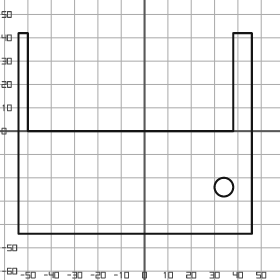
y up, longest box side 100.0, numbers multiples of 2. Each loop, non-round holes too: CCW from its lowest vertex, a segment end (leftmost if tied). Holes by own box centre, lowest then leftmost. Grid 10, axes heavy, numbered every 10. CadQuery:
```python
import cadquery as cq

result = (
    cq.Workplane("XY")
    .moveTo(-54.0, -44.0)
    .lineTo(46.0, -44.0)
    .lineTo(46.0, 42.0)
    .lineTo(38.0, 42.0)
    .lineTo(38.0, 0.0)
    .lineTo(-50.0, 0.0)
    .lineTo(-50.0, 42.0)
    .lineTo(-54.0, 42.0)
    .close()
    .moveTo(34.0, -24.0)
    .circle(4.0)
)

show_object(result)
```